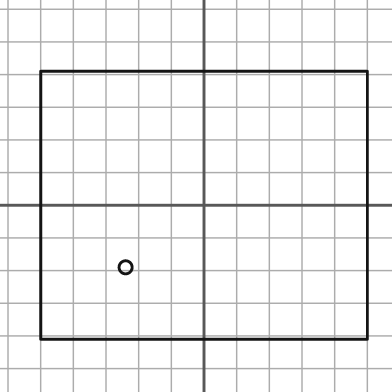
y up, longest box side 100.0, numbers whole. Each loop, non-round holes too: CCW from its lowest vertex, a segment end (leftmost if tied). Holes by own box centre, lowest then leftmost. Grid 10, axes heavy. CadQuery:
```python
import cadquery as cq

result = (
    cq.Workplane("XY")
    .moveTo(-50.0, -41.0)
    .lineTo(50.0, -41.0)
    .lineTo(50.0, 41.0)
    .lineTo(-50.0, 41.0)
    .close()
    .moveTo(-24.0, -19.0)
    .circle(2.0)
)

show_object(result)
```